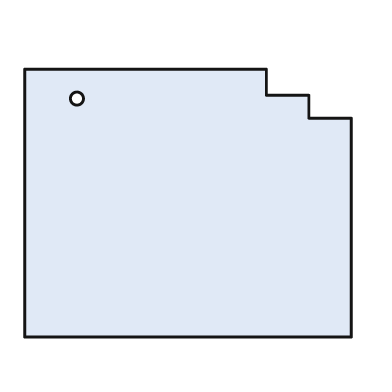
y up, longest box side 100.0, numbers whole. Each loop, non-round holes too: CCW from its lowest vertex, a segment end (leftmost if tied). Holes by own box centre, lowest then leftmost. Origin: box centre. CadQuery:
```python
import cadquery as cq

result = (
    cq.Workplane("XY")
    .moveTo(-50.0, -41.0)
    .lineTo(50.0, -41.0)
    .lineTo(50.0, 26.0)
    .lineTo(37.0, 26.0)
    .lineTo(37.0, 33.0)
    .lineTo(24.0, 33.0)
    .lineTo(24.0, 41.0)
    .lineTo(-50.0, 41.0)
    .close()
    .moveTo(-34.0, 32.0)
    .circle(2.0)
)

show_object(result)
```